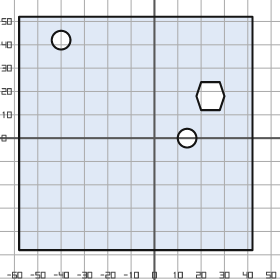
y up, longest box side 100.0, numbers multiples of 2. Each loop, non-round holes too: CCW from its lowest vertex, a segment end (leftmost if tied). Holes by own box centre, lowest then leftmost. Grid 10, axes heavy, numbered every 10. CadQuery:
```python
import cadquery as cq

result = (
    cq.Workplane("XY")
    .moveTo(-58.0, -48.0)
    .lineTo(42.0, -48.0)
    .lineTo(42.0, 52.0)
    .lineTo(-58.0, 52.0)
    .close()
    .moveTo(14.0, 0.0)
    .circle(4.0)
    .moveTo(20.0, 12.0)
    .lineTo(28.0, 12.0)
    .lineTo(30.0, 18.0)
    .lineTo(28.0, 24.0)
    .lineTo(20.0, 24.0)
    .lineTo(18.0, 18.0)
    .close()
    .moveTo(-40.0, 42.0)
    .circle(4.0)
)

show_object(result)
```